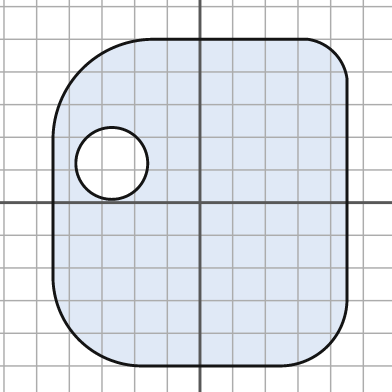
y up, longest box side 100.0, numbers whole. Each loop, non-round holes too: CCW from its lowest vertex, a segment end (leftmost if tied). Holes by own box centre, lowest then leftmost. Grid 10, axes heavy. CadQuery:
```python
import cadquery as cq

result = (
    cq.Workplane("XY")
    .moveTo(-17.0, -50.0)
    .lineTo(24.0, -50.0)
    .threePointArc((39.0, -44.0), (45.0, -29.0))
    .lineTo(45.0, 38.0)
    .threePointArc((41.0, 46.0), (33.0, 50.0))
    .lineTo(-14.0, 50.0)
    .threePointArc((-36.0, 41.0), (-45.0, 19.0))
    .lineTo(-45.0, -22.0)
    .threePointArc((-37.0, -42.0), (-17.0, -50.0))
    .close()
    .moveTo(-27.0, 12.0)
    .circle(11.0)
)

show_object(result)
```